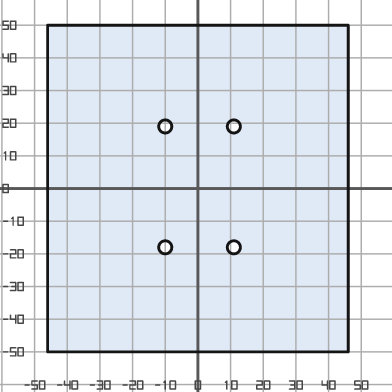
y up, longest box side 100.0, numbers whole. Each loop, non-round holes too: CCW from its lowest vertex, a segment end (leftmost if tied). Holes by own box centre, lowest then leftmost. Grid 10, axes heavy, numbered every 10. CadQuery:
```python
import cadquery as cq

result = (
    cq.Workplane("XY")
    .moveTo(-46.0, -50.0)
    .lineTo(46.0, -50.0)
    .lineTo(46.0, 50.0)
    .lineTo(-46.0, 50.0)
    .close()
    .moveTo(-10.0, -18.0)
    .circle(2.0)
    .moveTo(11.0, -18.0)
    .circle(2.0)
    .moveTo(-10.0, 19.0)
    .circle(2.0)
    .moveTo(11.0, 19.0)
    .circle(2.0)
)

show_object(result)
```